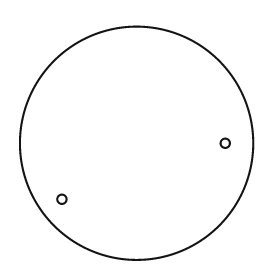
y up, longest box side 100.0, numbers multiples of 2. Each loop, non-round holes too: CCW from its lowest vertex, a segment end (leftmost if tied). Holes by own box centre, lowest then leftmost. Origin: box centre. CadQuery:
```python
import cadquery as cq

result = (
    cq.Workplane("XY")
    .moveTo(0.0, 0.0)
    .circle(50.0)
    .moveTo(-32.0, -24.0)
    .circle(2.0)
    .moveTo(38.0, 0.0)
    .circle(2.0)
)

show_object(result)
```